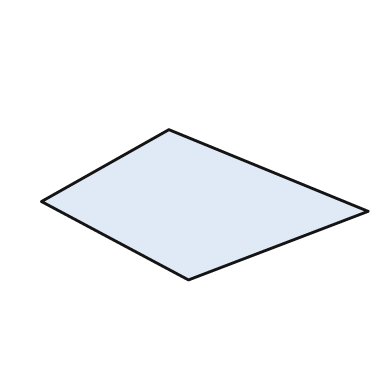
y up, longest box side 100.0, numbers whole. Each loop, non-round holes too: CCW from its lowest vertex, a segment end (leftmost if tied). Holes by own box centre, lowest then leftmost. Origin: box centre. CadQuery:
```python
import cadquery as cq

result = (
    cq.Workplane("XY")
    .moveTo(-5.0, -23.0)
    .lineTo(50.0, -2.0)
    .lineTo(-11.0, 23.0)
    .lineTo(-50.0, 1.0)
    .close()
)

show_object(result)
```